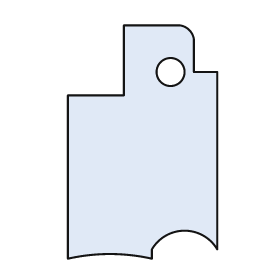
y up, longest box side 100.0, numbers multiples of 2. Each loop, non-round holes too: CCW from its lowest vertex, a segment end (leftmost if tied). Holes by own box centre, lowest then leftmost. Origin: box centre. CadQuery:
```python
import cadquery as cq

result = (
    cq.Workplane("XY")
    .moveTo(-32.0, -50.0)
    .threePointArc((-14.0, -48.0), (4.0, -50.0))
    .lineTo(4.0, -46.0)
    .threePointArc((18.0, -38.0), (32.0, -46.0))
    .lineTo(32.0, 30.0)
    .lineTo(22.0, 30.0)
    .lineTo(22.0, 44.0)
    .threePointArc((20.0, 48.0), (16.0, 50.0))
    .lineTo(-8.0, 50.0)
    .lineTo(-8.0, 20.0)
    .lineTo(-32.0, 20.0)
    .close()
    .moveTo(12.0, 30.0)
    .circle(6.0)
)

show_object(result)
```